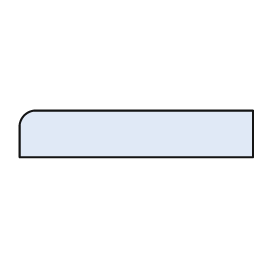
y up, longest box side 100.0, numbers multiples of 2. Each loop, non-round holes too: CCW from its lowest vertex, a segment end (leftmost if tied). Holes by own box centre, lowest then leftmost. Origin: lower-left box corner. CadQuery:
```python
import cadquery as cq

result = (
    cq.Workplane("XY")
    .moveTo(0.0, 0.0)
    .lineTo(100.0, 0.0)
    .lineTo(100.0, 20.0)
    .lineTo(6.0, 20.0)
    .threePointArc((2.0, 18.0), (0.0, 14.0))
    .close()
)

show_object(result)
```